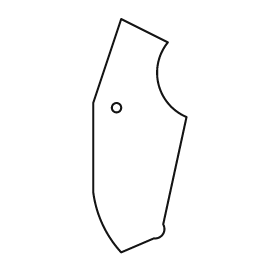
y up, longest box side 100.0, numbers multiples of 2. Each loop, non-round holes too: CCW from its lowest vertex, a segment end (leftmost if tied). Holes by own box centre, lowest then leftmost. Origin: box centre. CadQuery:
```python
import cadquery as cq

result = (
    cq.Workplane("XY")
    .moveTo(-8.0, -50.0)
    .lineTo(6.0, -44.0)
    .threePointArc((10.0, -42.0), (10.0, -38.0))
    .lineTo(20.0, 8.0)
    .threePointArc((8.0, 22.0), (12.0, 40.0))
    .lineTo(-8.0, 50.0)
    .lineTo(-20.0, 14.0)
    .lineTo(-20.0, -24.0)
    .threePointArc((-16.0, -38.0), (-8.0, -50.0))
    .close()
    .moveTo(-10.0, 12.0)
    .circle(2.0)
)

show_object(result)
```